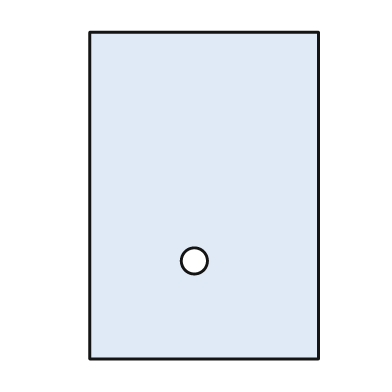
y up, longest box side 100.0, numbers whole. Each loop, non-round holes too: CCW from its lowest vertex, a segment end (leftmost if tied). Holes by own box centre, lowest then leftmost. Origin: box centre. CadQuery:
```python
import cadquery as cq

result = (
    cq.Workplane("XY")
    .moveTo(-35.0, -50.0)
    .lineTo(35.0, -50.0)
    .lineTo(35.0, 50.0)
    .lineTo(-35.0, 50.0)
    .close()
    .moveTo(-3.0, -20.0)
    .circle(4.0)
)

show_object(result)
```